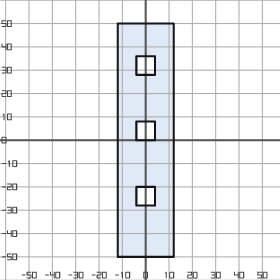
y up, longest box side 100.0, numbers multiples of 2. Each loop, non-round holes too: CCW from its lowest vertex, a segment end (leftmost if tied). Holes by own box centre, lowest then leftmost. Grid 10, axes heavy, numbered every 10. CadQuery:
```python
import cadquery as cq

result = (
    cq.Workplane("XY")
    .moveTo(-12.0, -50.0)
    .lineTo(12.0, -50.0)
    .lineTo(12.0, 50.0)
    .lineTo(-12.0, 50.0)
    .close()
    .moveTo(-4.0, -28.0)
    .lineTo(4.0, -28.0)
    .lineTo(4.0, -20.0)
    .lineTo(-4.0, -20.0)
    .close()
    .moveTo(-4.0, 0.0)
    .lineTo(4.0, 0.0)
    .lineTo(4.0, 8.0)
    .lineTo(-4.0, 8.0)
    .close()
    .moveTo(-4.0, 28.0)
    .lineTo(4.0, 28.0)
    .lineTo(4.0, 36.0)
    .lineTo(-4.0, 36.0)
    .close()
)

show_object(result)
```